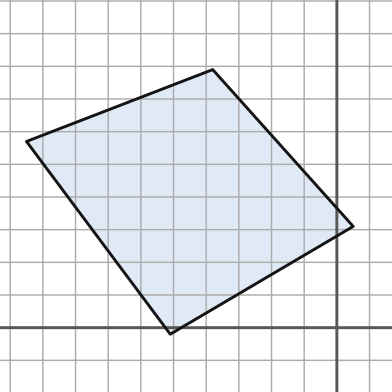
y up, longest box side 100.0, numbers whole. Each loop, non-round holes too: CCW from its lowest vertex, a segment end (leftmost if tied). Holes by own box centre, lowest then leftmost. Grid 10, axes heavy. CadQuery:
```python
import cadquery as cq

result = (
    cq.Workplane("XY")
    .moveTo(-51.0, -2.0)
    .lineTo(5.0, 31.0)
    .lineTo(-38.0, 79.0)
    .lineTo(-95.0, 57.0)
    .close()
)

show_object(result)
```